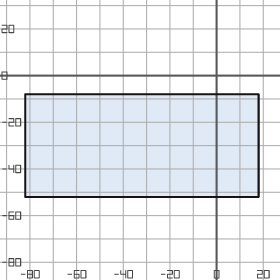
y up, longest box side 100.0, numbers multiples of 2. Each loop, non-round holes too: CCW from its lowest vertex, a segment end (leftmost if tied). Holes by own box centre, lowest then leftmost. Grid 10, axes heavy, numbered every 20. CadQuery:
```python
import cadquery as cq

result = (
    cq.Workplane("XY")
    .moveTo(-82.0, -52.0)
    .lineTo(18.0, -52.0)
    .lineTo(18.0, -8.0)
    .lineTo(-82.0, -8.0)
    .close()
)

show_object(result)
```